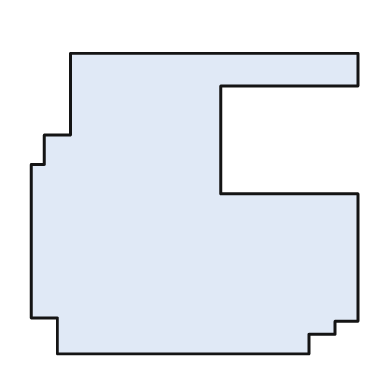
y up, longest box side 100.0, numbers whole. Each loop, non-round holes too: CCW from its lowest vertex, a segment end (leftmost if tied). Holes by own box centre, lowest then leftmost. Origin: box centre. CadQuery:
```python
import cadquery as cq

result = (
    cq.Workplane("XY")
    .moveTo(-42.0, -46.0)
    .lineTo(35.0, -46.0)
    .lineTo(35.0, -40.0)
    .lineTo(43.0, -40.0)
    .lineTo(43.0, -36.0)
    .lineTo(50.0, -36.0)
    .lineTo(50.0, 3.0)
    .lineTo(8.0, 3.0)
    .lineTo(8.0, 36.0)
    .lineTo(50.0, 36.0)
    .lineTo(50.0, 46.0)
    .lineTo(-38.0, 46.0)
    .lineTo(-38.0, 21.0)
    .lineTo(-46.0, 21.0)
    .lineTo(-46.0, 12.0)
    .lineTo(-50.0, 12.0)
    .lineTo(-50.0, -35.0)
    .lineTo(-42.0, -35.0)
    .close()
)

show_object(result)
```